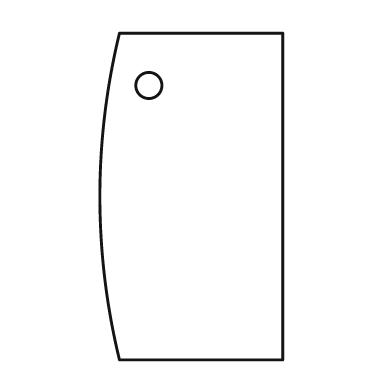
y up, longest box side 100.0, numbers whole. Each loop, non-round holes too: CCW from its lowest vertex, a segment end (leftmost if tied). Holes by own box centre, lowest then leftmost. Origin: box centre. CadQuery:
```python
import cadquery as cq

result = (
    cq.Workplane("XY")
    .moveTo(-22.0, -50.0)
    .lineTo(28.0, -50.0)
    .lineTo(28.0, 50.0)
    .lineTo(-22.0, 50.0)
    .threePointArc((-28.0, 0.0), (-22.0, -50.0))
    .close()
    .moveTo(-13.0, 34.0)
    .circle(4.0)
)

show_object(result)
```